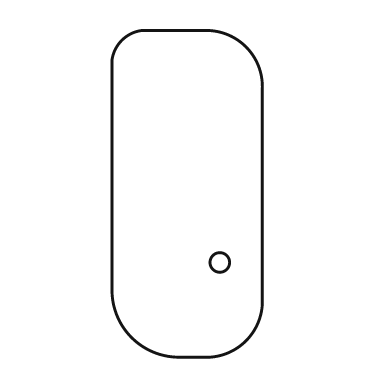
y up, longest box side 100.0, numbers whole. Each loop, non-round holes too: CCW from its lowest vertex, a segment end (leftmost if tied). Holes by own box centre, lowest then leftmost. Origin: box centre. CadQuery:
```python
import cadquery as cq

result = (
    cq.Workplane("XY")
    .moveTo(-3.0, -50.0)
    .lineTo(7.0, -50.0)
    .threePointArc((18.0, -45.0), (23.0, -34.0))
    .lineTo(23.0, 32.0)
    .threePointArc((18.0, 45.0), (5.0, 50.0))
    .lineTo(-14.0, 50.0)
    .threePointArc((-20.0, 47.0), (-23.0, 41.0))
    .lineTo(-23.0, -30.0)
    .threePointArc((-17.0, -44.0), (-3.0, -50.0))
    .close()
    .moveTo(10.0, -21.0)
    .circle(3.0)
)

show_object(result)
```